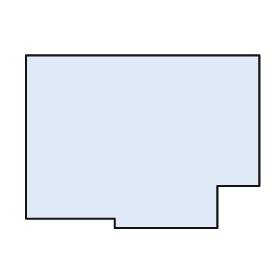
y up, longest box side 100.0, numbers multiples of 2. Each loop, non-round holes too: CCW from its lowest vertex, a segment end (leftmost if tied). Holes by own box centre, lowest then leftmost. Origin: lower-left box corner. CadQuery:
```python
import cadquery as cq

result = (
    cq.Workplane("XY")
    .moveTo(38.0, 0.0)
    .lineTo(82.0, 0.0)
    .lineTo(82.0, 18.0)
    .lineTo(100.0, 18.0)
    .lineTo(100.0, 74.0)
    .lineTo(0.0, 74.0)
    .lineTo(0.0, 4.0)
    .lineTo(38.0, 4.0)
    .close()
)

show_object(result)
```